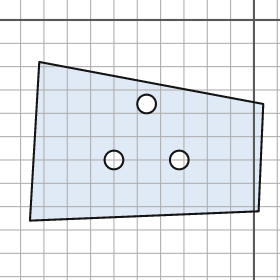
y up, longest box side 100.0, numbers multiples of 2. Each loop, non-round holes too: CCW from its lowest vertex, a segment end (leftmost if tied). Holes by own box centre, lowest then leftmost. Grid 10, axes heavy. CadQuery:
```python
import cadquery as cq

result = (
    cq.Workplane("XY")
    .moveTo(-96.0, -86.0)
    .lineTo(2.0, -82.0)
    .lineTo(4.0, -36.0)
    .lineTo(-92.0, -18.0)
    .close()
    .moveTo(-60.0, -60.0)
    .circle(4.0)
    .moveTo(-32.0, -60.0)
    .circle(4.0)
    .moveTo(-46.0, -36.0)
    .circle(4.0)
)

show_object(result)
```